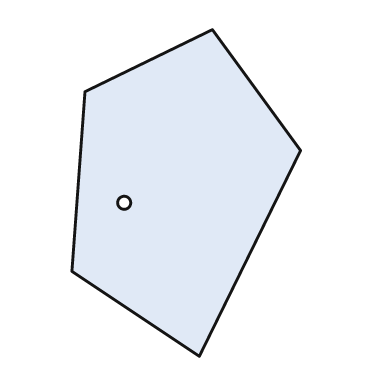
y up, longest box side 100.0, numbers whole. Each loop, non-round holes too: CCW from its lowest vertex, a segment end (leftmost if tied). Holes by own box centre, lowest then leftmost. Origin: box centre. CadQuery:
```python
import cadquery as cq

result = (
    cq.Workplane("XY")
    .moveTo(4.0, -50.0)
    .lineTo(35.0, 13.0)
    .lineTo(8.0, 50.0)
    .lineTo(-31.0, 31.0)
    .lineTo(-35.0, -24.0)
    .close()
    .moveTo(-19.0, -3.0)
    .circle(2.0)
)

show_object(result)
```